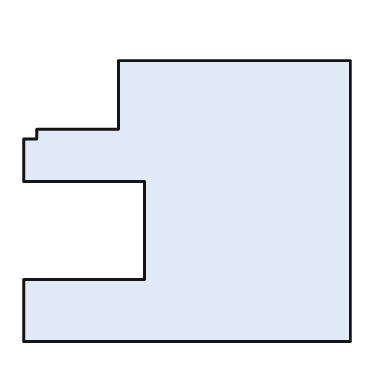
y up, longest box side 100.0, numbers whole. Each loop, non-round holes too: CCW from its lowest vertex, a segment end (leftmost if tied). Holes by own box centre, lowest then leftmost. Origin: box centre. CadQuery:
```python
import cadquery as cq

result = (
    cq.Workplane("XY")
    .moveTo(-50.0, -43.0)
    .lineTo(50.0, -43.0)
    .lineTo(50.0, 43.0)
    .lineTo(-21.0, 43.0)
    .lineTo(-21.0, 22.0)
    .lineTo(-46.0, 22.0)
    .lineTo(-46.0, 19.0)
    .lineTo(-50.0, 19.0)
    .lineTo(-50.0, 6.0)
    .lineTo(-13.0, 6.0)
    .lineTo(-13.0, -24.0)
    .lineTo(-50.0, -24.0)
    .close()
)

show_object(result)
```